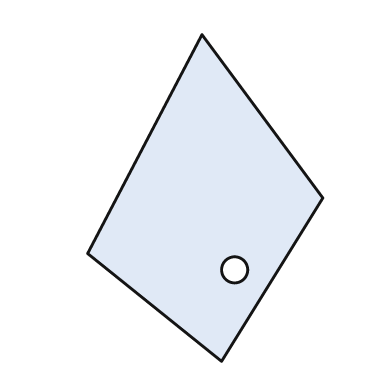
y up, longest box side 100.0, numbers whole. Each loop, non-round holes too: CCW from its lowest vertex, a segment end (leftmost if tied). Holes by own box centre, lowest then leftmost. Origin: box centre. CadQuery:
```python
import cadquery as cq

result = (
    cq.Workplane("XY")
    .moveTo(5.0, -50.0)
    .lineTo(36.0, 0.0)
    .lineTo(-1.0, 50.0)
    .lineTo(-36.0, -17.0)
    .close()
    .moveTo(9.0, -22.0)
    .circle(4.0)
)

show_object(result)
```